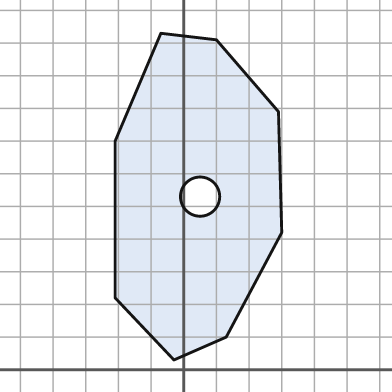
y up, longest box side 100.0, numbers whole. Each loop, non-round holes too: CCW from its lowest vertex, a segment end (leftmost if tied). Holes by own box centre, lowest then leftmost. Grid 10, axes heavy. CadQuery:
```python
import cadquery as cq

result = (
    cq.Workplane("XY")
    .moveTo(-3.0, 3.0)
    .lineTo(13.0, 10.0)
    .lineTo(30.0, 42.0)
    .lineTo(29.0, 79.0)
    .lineTo(10.0, 101.0)
    .lineTo(-7.0, 103.0)
    .lineTo(-21.0, 70.0)
    .lineTo(-21.0, 22.0)
    .close()
    .moveTo(5.0, 53.0)
    .circle(6.0)
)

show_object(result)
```